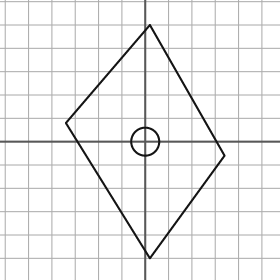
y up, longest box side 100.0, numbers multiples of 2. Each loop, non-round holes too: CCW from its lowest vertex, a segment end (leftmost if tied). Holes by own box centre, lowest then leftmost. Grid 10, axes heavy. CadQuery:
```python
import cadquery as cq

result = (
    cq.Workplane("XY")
    .moveTo(2.0, -50.0)
    .lineTo(34.0, -6.0)
    .lineTo(2.0, 50.0)
    .lineTo(-34.0, 8.0)
    .close()
    .moveTo(0.0, 0.0)
    .circle(6.0)
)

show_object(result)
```